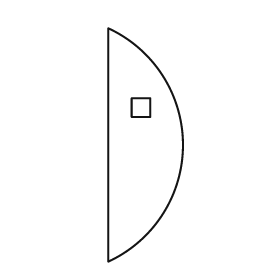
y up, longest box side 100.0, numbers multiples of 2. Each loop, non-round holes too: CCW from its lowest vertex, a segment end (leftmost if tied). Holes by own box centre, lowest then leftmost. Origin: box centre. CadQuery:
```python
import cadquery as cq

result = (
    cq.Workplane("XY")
    .moveTo(-16.0, -50.0)
    .threePointArc((16.0, 0.0), (-16.0, 50.0))
    .close()
    .moveTo(-6.0, 12.0)
    .lineTo(2.0, 12.0)
    .lineTo(2.0, 20.0)
    .lineTo(-6.0, 20.0)
    .close()
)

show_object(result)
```